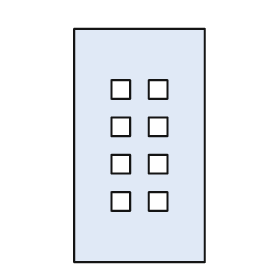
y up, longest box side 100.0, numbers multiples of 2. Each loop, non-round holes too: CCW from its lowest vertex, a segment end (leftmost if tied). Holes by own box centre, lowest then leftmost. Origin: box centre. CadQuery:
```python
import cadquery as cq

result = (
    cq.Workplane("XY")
    .moveTo(-28.0, -50.0)
    .lineTo(28.0, -50.0)
    .lineTo(28.0, 50.0)
    .lineTo(-28.0, 50.0)
    .close()
    .moveTo(-12.0, -28.0)
    .lineTo(-4.0, -28.0)
    .lineTo(-4.0, -20.0)
    .lineTo(-12.0, -20.0)
    .close()
    .moveTo(4.0, -28.0)
    .lineTo(12.0, -28.0)
    .lineTo(12.0, -20.0)
    .lineTo(4.0, -20.0)
    .close()
    .moveTo(-12.0, -12.0)
    .lineTo(-4.0, -12.0)
    .lineTo(-4.0, -4.0)
    .lineTo(-12.0, -4.0)
    .close()
    .moveTo(4.0, -12.0)
    .lineTo(12.0, -12.0)
    .lineTo(12.0, -4.0)
    .lineTo(4.0, -4.0)
    .close()
    .moveTo(-12.0, 4.0)
    .lineTo(-4.0, 4.0)
    .lineTo(-4.0, 12.0)
    .lineTo(-12.0, 12.0)
    .close()
    .moveTo(4.0, 4.0)
    .lineTo(12.0, 4.0)
    .lineTo(12.0, 12.0)
    .lineTo(4.0, 12.0)
    .close()
    .moveTo(-12.0, 20.0)
    .lineTo(-4.0, 20.0)
    .lineTo(-4.0, 28.0)
    .lineTo(-12.0, 28.0)
    .close()
    .moveTo(4.0, 20.0)
    .lineTo(12.0, 20.0)
    .lineTo(12.0, 28.0)
    .lineTo(4.0, 28.0)
    .close()
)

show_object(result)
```